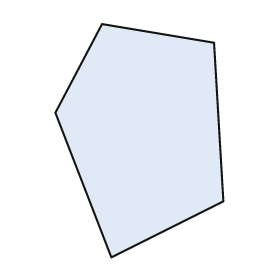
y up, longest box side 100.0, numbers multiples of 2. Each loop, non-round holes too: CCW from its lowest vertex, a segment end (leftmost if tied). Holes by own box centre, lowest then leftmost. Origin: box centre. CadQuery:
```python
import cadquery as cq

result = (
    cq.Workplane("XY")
    .moveTo(-12.0, -50.0)
    .lineTo(36.0, -26.0)
    .lineTo(32.0, 42.0)
    .lineTo(-16.0, 50.0)
    .lineTo(-36.0, 12.0)
    .close()
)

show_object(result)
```